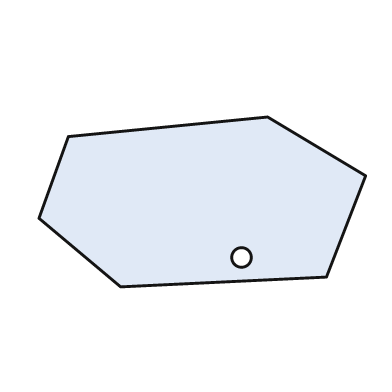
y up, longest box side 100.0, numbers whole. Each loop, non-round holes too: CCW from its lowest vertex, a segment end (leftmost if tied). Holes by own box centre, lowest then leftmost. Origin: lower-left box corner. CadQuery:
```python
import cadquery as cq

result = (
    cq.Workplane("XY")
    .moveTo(25.0, 0.0)
    .lineTo(88.0, 3.0)
    .lineTo(100.0, 34.0)
    .lineTo(70.0, 52.0)
    .lineTo(9.0, 46.0)
    .lineTo(0.0, 21.0)
    .close()
    .moveTo(62.0, 9.0)
    .circle(3.0)
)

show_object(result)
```